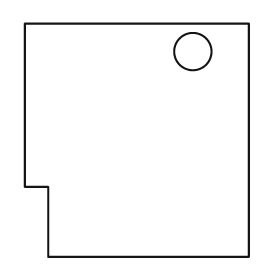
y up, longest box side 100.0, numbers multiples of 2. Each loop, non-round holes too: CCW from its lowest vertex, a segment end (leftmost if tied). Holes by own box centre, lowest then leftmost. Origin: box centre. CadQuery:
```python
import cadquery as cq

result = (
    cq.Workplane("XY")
    .moveTo(-38.0, -50.0)
    .lineTo(48.0, -50.0)
    .lineTo(48.0, 50.0)
    .lineTo(-48.0, 50.0)
    .lineTo(-48.0, -20.0)
    .lineTo(-38.0, -20.0)
    .close()
    .moveTo(24.0, 38.0)
    .circle(8.0)
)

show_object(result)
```